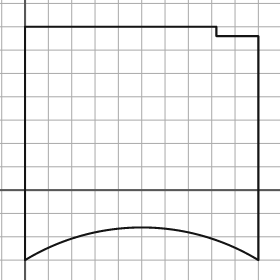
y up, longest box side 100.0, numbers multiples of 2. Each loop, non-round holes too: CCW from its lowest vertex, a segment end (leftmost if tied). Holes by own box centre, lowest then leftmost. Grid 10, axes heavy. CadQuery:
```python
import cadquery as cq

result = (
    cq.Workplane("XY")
    .moveTo(0.0, -30.0)
    .threePointArc((50.0, -16.0), (100.0, -30.0))
    .lineTo(100.0, 66.0)
    .lineTo(82.0, 66.0)
    .lineTo(82.0, 70.0)
    .lineTo(0.0, 70.0)
    .close()
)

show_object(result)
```